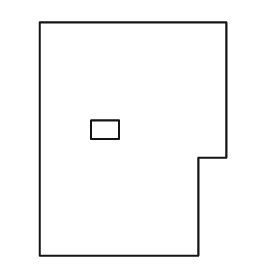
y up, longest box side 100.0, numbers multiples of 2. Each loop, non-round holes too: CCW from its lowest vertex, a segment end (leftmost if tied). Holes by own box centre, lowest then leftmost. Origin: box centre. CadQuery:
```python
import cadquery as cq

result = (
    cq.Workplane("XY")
    .moveTo(-40.0, -50.0)
    .lineTo(28.0, -50.0)
    .lineTo(28.0, -8.0)
    .lineTo(40.0, -8.0)
    .lineTo(40.0, 50.0)
    .lineTo(-40.0, 50.0)
    .close()
    .moveTo(-18.0, 0.0)
    .lineTo(-6.0, 0.0)
    .lineTo(-6.0, 8.0)
    .lineTo(-18.0, 8.0)
    .close()
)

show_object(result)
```